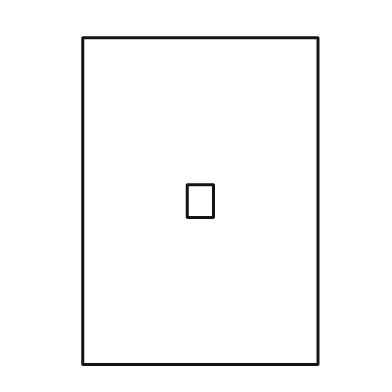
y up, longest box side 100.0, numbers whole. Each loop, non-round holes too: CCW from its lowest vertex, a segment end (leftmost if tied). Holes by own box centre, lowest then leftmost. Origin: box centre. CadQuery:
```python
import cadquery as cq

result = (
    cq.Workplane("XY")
    .moveTo(-36.0, -50.0)
    .lineTo(36.0, -50.0)
    .lineTo(36.0, 50.0)
    .lineTo(-36.0, 50.0)
    .close()
    .moveTo(-4.0, -5.0)
    .lineTo(4.0, -5.0)
    .lineTo(4.0, 5.0)
    .lineTo(-4.0, 5.0)
    .close()
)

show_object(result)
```